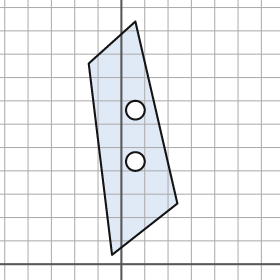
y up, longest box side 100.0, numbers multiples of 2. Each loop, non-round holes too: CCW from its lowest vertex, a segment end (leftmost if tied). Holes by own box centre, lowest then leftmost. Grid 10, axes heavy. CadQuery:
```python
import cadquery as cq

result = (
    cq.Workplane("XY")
    .moveTo(-4.0, 4.0)
    .lineTo(24.0, 26.0)
    .lineTo(6.0, 104.0)
    .lineTo(-14.0, 86.0)
    .close()
    .moveTo(6.0, 44.0)
    .circle(4.0)
    .moveTo(6.0, 66.0)
    .circle(4.0)
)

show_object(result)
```